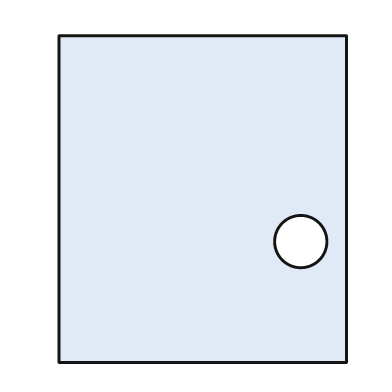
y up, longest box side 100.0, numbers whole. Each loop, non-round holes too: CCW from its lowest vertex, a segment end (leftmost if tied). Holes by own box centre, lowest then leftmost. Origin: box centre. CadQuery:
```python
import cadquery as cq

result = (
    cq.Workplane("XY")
    .moveTo(-44.0, -50.0)
    .lineTo(44.0, -50.0)
    .lineTo(44.0, 50.0)
    .lineTo(-44.0, 50.0)
    .close()
    .moveTo(30.0, -13.0)
    .circle(8.0)
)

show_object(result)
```